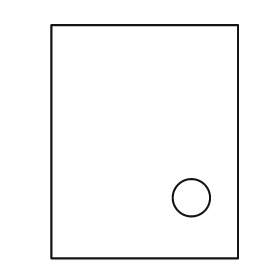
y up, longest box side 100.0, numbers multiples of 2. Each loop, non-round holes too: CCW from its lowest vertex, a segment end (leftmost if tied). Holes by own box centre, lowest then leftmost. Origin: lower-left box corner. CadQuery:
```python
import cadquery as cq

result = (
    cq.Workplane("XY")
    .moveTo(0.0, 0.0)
    .lineTo(80.0, 0.0)
    .lineTo(80.0, 100.0)
    .lineTo(0.0, 100.0)
    .close()
    .moveTo(60.0, 26.0)
    .circle(8.0)
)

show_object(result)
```